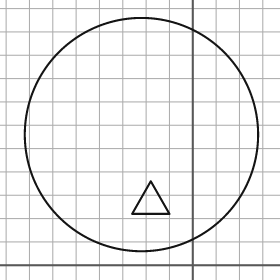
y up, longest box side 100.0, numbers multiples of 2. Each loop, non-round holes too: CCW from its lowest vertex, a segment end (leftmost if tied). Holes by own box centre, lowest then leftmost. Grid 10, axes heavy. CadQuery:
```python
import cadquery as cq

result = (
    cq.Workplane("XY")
    .moveTo(-22.0, 56.0)
    .circle(50.0)
    .moveTo(-26.0, 22.0)
    .lineTo(-10.0, 22.0)
    .lineTo(-18.0, 36.0)
    .close()
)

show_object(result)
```